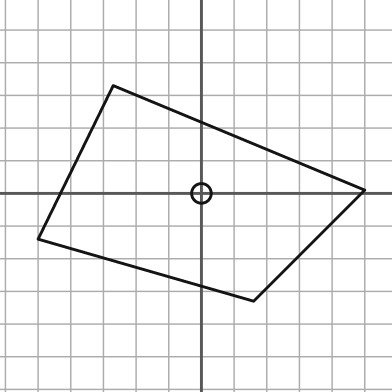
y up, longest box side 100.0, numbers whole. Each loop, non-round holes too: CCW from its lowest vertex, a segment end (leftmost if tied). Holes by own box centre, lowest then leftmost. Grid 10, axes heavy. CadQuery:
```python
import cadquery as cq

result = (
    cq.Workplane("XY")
    .moveTo(16.0, -33.0)
    .lineTo(50.0, 1.0)
    .lineTo(-27.0, 33.0)
    .lineTo(-50.0, -14.0)
    .close()
    .moveTo(0.0, 0.0)
    .circle(3.0)
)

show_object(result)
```